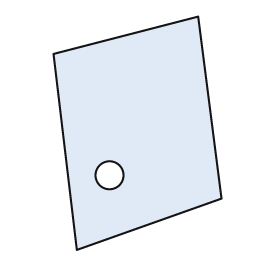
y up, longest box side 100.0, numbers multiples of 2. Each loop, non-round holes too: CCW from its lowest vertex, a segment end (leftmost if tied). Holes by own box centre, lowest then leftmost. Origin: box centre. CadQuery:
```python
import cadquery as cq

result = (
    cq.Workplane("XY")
    .moveTo(-26.0, -50.0)
    .lineTo(36.0, -28.0)
    .lineTo(26.0, 50.0)
    .lineTo(-36.0, 34.0)
    .close()
    .moveTo(-12.0, -18.0)
    .circle(6.0)
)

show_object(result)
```